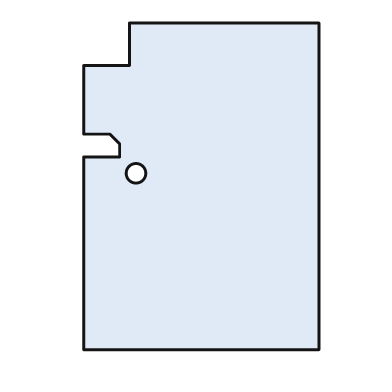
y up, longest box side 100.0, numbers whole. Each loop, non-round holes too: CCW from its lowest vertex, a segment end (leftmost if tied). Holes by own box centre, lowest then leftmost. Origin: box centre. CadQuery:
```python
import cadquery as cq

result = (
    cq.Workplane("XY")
    .moveTo(-36.0, -50.0)
    .lineTo(36.0, -50.0)
    .lineTo(36.0, 50.0)
    .lineTo(-22.0, 50.0)
    .lineTo(-22.0, 37.0)
    .lineTo(-36.0, 37.0)
    .lineTo(-36.0, 16.0)
    .lineTo(-28.0, 16.0)
    .lineTo(-25.0, 13.0)
    .lineTo(-25.0, 9.0)
    .lineTo(-36.0, 9.0)
    .close()
    .moveTo(-20.0, 4.0)
    .circle(3.0)
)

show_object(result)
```